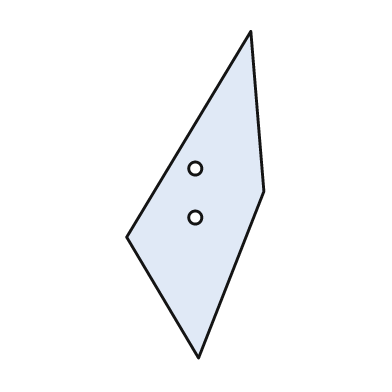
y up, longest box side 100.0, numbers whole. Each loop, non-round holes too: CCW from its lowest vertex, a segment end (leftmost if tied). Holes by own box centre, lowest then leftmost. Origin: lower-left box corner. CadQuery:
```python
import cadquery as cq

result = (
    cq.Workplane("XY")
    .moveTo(22.0, 0.0)
    .lineTo(42.0, 51.0)
    .lineTo(38.0, 100.0)
    .lineTo(0.0, 37.0)
    .close()
    .moveTo(21.0, 43.0)
    .circle(2.0)
    .moveTo(21.0, 58.0)
    .circle(2.0)
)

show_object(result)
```